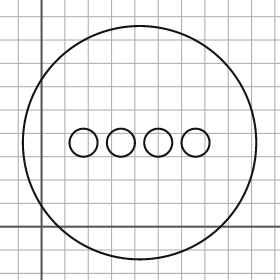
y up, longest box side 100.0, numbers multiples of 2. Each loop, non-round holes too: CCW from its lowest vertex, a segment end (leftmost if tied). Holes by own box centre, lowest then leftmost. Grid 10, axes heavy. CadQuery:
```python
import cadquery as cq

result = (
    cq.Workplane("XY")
    .moveTo(42.0, 36.0)
    .circle(50.0)
    .moveTo(18.0, 36.0)
    .circle(6.0)
    .moveTo(34.0, 36.0)
    .circle(6.0)
    .moveTo(50.0, 36.0)
    .circle(6.0)
    .moveTo(66.0, 36.0)
    .circle(6.0)
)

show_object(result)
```